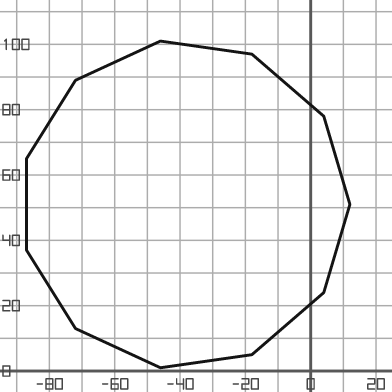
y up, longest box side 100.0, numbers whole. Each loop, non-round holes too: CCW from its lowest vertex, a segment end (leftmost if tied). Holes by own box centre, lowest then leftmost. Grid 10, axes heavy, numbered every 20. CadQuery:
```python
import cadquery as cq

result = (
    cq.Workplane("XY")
    .moveTo(-46.0, 1.0)
    .lineTo(-18.0, 5.0)
    .lineTo(4.0, 24.0)
    .lineTo(12.0, 51.0)
    .lineTo(4.0, 78.0)
    .lineTo(-18.0, 97.0)
    .lineTo(-46.0, 101.0)
    .lineTo(-72.0, 89.0)
    .lineTo(-87.0, 65.0)
    .lineTo(-87.0, 37.0)
    .lineTo(-72.0, 13.0)
    .close()
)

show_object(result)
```